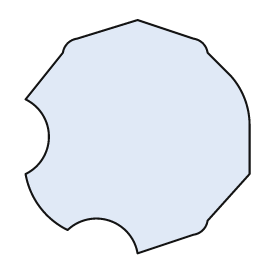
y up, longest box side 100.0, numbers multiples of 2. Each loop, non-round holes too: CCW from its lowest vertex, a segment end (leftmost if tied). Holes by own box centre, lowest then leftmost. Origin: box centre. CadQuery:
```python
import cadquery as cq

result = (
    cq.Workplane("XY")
    .moveTo(0.0, -50.0)
    .lineTo(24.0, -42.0)
    .threePointArc((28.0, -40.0), (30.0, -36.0))
    .lineTo(48.0, -16.0)
    .lineTo(48.0, 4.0)
    .threePointArc((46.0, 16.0), (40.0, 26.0))
    .lineTo(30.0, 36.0)
    .threePointArc((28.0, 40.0), (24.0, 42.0))
    .lineTo(0.0, 50.0)
    .lineTo(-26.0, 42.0)
    .threePointArc((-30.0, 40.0), (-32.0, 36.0))
    .lineTo(-48.0, 16.0)
    .threePointArc((-38.0, 0.0), (-48.0, -16.0))
    .threePointArc((-42.0, -30.0), (-30.0, -40.0))
    .threePointArc((-12.0, -36.0), (0.0, -50.0))
    .close()
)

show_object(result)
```